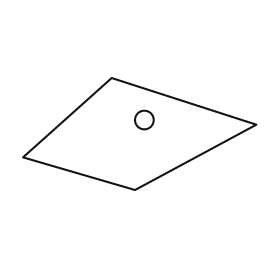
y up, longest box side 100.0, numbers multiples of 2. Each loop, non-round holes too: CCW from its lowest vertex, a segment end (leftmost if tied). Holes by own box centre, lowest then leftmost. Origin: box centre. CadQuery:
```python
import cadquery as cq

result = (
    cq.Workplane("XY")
    .moveTo(-2.0, -24.0)
    .lineTo(50.0, 4.0)
    .lineTo(-12.0, 24.0)
    .lineTo(-50.0, -10.0)
    .close()
    .moveTo(2.0, 6.0)
    .circle(4.0)
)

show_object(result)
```